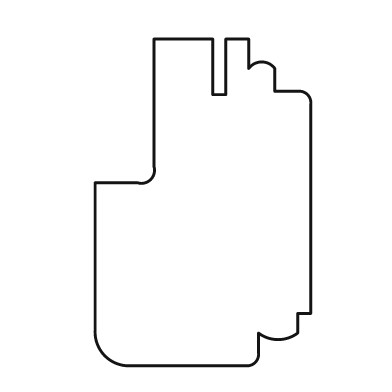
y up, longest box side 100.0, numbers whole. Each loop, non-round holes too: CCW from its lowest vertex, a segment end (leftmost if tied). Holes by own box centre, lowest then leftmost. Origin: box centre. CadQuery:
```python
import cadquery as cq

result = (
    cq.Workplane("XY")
    .moveTo(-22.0, -50.0)
    .lineTo(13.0, -50.0)
    .threePointArc((16.0, -49.0), (17.0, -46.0))
    .lineTo(17.0, -40.0)
    .threePointArc((23.0, -42.0), (29.0, -40.0))
    .lineTo(29.0, -34.0)
    .lineTo(33.0, -34.0)
    .lineTo(33.0, 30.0)
    .threePointArc((32.0, 33.0), (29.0, 34.0))
    .lineTo(22.0, 34.0)
    .lineTo(22.0, 41.0)
    .threePointArc((18.0, 43.0), (14.0, 41.0))
    .lineTo(14.0, 50.0)
    .lineTo(7.0, 50.0)
    .lineTo(7.0, 33.0)
    .lineTo(3.0, 33.0)
    .lineTo(3.0, 50.0)
    .lineTo(-15.0, 50.0)
    .lineTo(-15.0, 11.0)
    .threePointArc((-16.0, 7.0), (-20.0, 6.0))
    .lineTo(-33.0, 6.0)
    .lineTo(-33.0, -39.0)
    .threePointArc((-30.0, -47.0), (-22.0, -50.0))
    .close()
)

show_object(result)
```